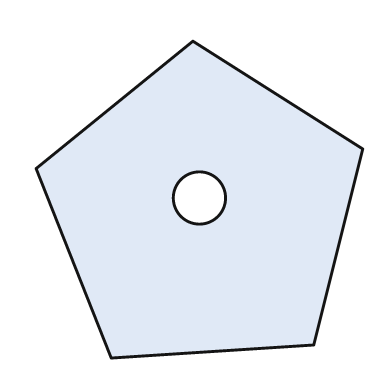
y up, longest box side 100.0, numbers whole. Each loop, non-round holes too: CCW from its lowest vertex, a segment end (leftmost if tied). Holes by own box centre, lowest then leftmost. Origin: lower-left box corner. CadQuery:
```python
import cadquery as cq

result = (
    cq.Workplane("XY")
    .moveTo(23.0, 0.0)
    .lineTo(85.0, 4.0)
    .lineTo(100.0, 64.0)
    .lineTo(48.0, 97.0)
    .lineTo(0.0, 58.0)
    .close()
    .moveTo(50.0, 49.0)
    .circle(8.0)
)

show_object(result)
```